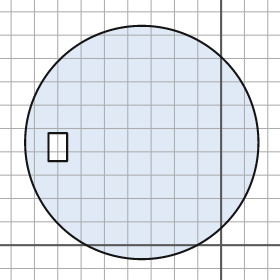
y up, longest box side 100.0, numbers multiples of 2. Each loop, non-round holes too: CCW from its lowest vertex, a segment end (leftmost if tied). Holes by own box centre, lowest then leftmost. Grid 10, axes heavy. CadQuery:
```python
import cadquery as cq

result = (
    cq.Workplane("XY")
    .moveTo(-34.0, 44.0)
    .circle(50.0)
    .moveTo(-74.0, 36.0)
    .lineTo(-66.0, 36.0)
    .lineTo(-66.0, 48.0)
    .lineTo(-74.0, 48.0)
    .close()
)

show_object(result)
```